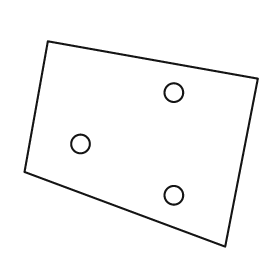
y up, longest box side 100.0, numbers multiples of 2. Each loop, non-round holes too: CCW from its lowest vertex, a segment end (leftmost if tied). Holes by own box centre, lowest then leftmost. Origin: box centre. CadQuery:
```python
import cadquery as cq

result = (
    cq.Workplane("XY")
    .moveTo(36.0, -44.0)
    .lineTo(50.0, 28.0)
    .lineTo(-40.0, 44.0)
    .lineTo(-50.0, -12.0)
    .close()
    .moveTo(14.0, -22.0)
    .circle(4.0)
    .moveTo(-26.0, 0.0)
    .circle(4.0)
    .moveTo(14.0, 22.0)
    .circle(4.0)
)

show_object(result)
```